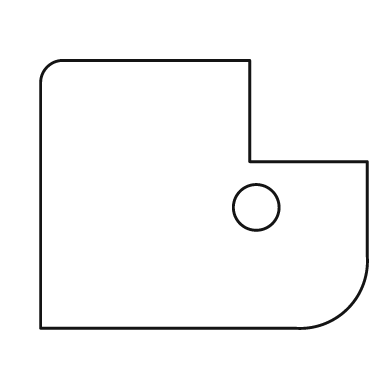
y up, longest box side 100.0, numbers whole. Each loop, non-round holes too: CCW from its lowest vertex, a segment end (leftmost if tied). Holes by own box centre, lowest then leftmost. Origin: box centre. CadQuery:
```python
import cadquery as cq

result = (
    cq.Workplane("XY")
    .moveTo(-50.0, -41.0)
    .lineTo(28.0, -41.0)
    .threePointArc((44.0, -35.0), (50.0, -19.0))
    .lineTo(50.0, 10.0)
    .lineTo(14.0, 10.0)
    .lineTo(14.0, 41.0)
    .lineTo(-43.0, 41.0)
    .threePointArc((-48.0, 39.0), (-50.0, 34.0))
    .close()
    .moveTo(16.0, -4.0)
    .circle(7.0)
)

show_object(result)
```